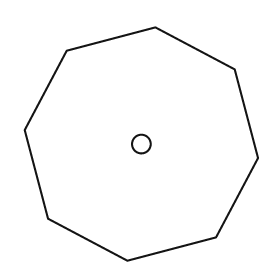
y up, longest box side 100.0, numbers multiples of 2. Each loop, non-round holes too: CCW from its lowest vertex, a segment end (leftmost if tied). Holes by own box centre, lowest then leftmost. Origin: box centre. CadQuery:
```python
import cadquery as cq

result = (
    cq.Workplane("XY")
    .moveTo(-6.0, -50.0)
    .lineTo(32.0, -40.0)
    .lineTo(50.0, -6.0)
    .lineTo(40.0, 32.0)
    .lineTo(6.0, 50.0)
    .lineTo(-32.0, 40.0)
    .lineTo(-50.0, 6.0)
    .lineTo(-40.0, -32.0)
    .close()
    .moveTo(0.0, 0.0)
    .circle(4.0)
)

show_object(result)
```